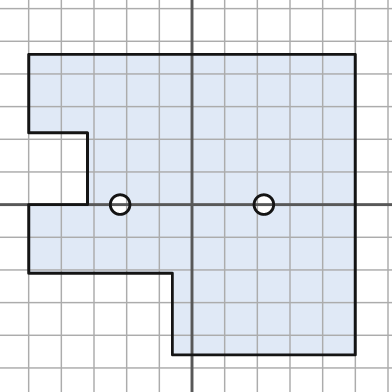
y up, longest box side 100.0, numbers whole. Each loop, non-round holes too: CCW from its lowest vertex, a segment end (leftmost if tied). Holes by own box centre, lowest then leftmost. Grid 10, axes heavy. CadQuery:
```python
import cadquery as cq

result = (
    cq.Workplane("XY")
    .moveTo(-6.0, -46.0)
    .lineTo(50.0, -46.0)
    .lineTo(50.0, 46.0)
    .lineTo(-50.0, 46.0)
    .lineTo(-50.0, 22.0)
    .lineTo(-32.0, 22.0)
    .lineTo(-32.0, 0.0)
    .lineTo(-50.0, 0.0)
    .lineTo(-50.0, -21.0)
    .lineTo(-6.0, -21.0)
    .close()
    .moveTo(-22.0, 0.0)
    .circle(3.0)
    .moveTo(22.0, 0.0)
    .circle(3.0)
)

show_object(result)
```